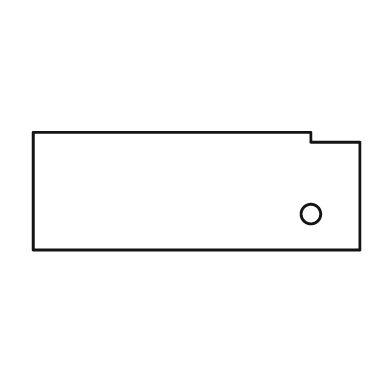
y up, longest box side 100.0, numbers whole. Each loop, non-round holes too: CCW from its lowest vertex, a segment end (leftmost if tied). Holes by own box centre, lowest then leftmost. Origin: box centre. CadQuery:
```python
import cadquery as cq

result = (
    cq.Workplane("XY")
    .moveTo(-50.0, -18.0)
    .lineTo(50.0, -18.0)
    .lineTo(50.0, 15.0)
    .lineTo(35.0, 15.0)
    .lineTo(35.0, 18.0)
    .lineTo(-50.0, 18.0)
    .close()
    .moveTo(35.0, -7.0)
    .circle(3.0)
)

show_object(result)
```